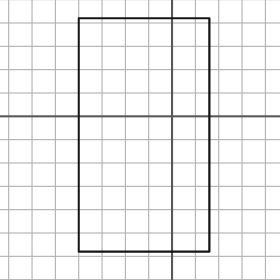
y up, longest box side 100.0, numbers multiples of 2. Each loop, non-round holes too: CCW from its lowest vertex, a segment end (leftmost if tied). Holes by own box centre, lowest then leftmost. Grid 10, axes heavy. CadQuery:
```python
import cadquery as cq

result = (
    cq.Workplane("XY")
    .moveTo(-40.0, -58.0)
    .lineTo(16.0, -58.0)
    .lineTo(16.0, 42.0)
    .lineTo(-40.0, 42.0)
    .close()
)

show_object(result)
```